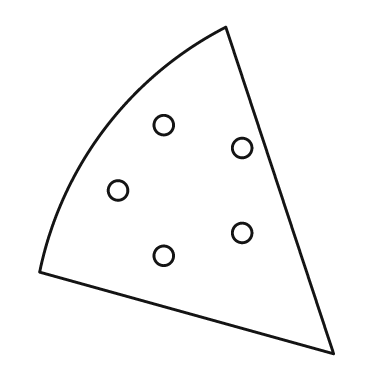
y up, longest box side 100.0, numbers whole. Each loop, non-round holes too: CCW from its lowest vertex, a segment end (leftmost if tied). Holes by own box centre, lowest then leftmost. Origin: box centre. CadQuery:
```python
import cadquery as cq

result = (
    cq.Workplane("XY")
    .moveTo(45.0, -50.0)
    .lineTo(12.0, 50.0)
    .threePointArc((-25.0, 19.0), (-45.0, -25.0))
    .close()
    .moveTo(-7.0, -20.0)
    .circle(3.0)
    .moveTo(17.0, -13.0)
    .circle(3.0)
    .moveTo(-21.0, 0.0)
    .circle(3.0)
    .moveTo(17.0, 13.0)
    .circle(3.0)
    .moveTo(-7.0, 20.0)
    .circle(3.0)
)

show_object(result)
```